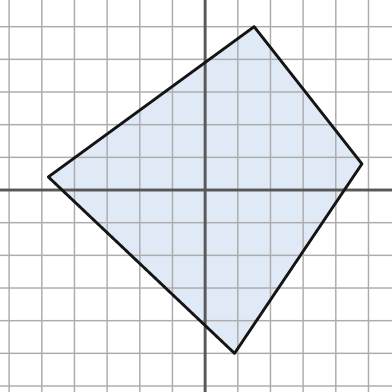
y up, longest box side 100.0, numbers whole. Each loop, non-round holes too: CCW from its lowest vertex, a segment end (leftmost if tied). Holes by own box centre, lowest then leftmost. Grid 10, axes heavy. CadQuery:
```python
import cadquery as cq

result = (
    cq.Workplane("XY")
    .moveTo(9.0, -50.0)
    .lineTo(48.0, 8.0)
    .lineTo(15.0, 50.0)
    .lineTo(-48.0, 4.0)
    .close()
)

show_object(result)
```